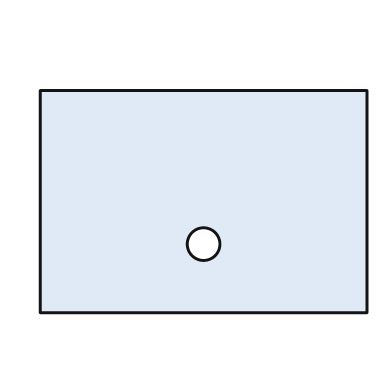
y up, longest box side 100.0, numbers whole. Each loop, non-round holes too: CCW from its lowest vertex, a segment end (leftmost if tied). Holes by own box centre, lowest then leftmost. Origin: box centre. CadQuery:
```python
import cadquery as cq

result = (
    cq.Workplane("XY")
    .moveTo(-50.0, -34.0)
    .lineTo(50.0, -34.0)
    .lineTo(50.0, 34.0)
    .lineTo(-50.0, 34.0)
    .close()
    .moveTo(0.0, -13.0)
    .circle(5.0)
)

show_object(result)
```